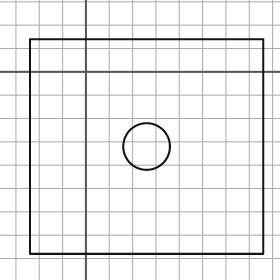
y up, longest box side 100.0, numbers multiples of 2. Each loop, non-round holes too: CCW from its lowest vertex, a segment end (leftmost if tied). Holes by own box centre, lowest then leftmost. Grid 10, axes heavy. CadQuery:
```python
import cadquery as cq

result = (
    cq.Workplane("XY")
    .moveTo(-24.0, -78.0)
    .lineTo(76.0, -78.0)
    .lineTo(76.0, 14.0)
    .lineTo(-24.0, 14.0)
    .close()
    .moveTo(26.0, -32.0)
    .circle(10.0)
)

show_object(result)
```